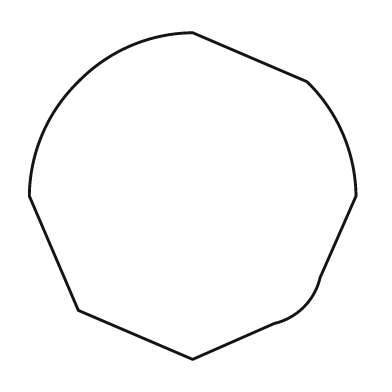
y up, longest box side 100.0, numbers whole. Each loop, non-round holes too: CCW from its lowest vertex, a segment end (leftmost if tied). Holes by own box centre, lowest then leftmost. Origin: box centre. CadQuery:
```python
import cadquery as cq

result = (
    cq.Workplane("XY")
    .moveTo(0.0, -50.0)
    .lineTo(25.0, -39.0)
    .threePointArc((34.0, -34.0), (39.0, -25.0))
    .lineTo(50.0, 0.0)
    .threePointArc((46.0, 19.0), (35.0, 35.0))
    .lineTo(0.0, 50.0)
    .threePointArc((-19.0, 46.0), (-35.0, 35.0))
    .threePointArc((-46.0, 19.0), (-50.0, 0.0))
    .lineTo(-35.0, -35.0)
    .close()
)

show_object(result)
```